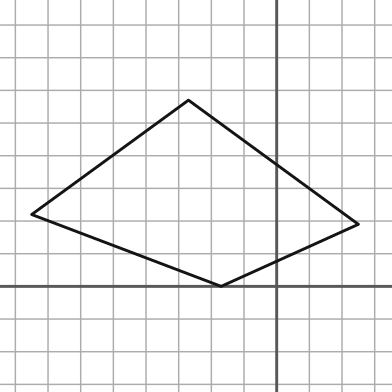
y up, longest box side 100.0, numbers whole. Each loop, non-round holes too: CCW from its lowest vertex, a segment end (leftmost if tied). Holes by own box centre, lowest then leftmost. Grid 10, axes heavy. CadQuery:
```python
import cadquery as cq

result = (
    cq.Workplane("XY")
    .moveTo(-17.0, 0.0)
    .lineTo(25.0, 19.0)
    .lineTo(-27.0, 57.0)
    .lineTo(-75.0, 22.0)
    .close()
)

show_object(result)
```